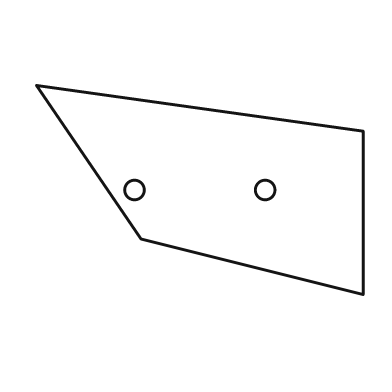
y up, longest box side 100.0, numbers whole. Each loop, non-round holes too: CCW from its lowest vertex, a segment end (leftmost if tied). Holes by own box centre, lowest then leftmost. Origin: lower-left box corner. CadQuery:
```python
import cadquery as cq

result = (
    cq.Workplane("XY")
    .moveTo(100.0, 0.0)
    .lineTo(100.0, 50.0)
    .lineTo(0.0, 64.0)
    .lineTo(32.0, 17.0)
    .close()
    .moveTo(30.0, 32.0)
    .circle(3.0)
    .moveTo(70.0, 32.0)
    .circle(3.0)
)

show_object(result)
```